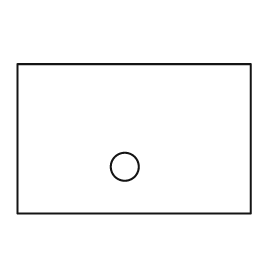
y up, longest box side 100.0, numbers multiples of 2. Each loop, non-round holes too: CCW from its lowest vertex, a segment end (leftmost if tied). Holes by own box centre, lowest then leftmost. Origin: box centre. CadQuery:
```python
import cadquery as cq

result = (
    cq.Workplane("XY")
    .moveTo(-50.0, -32.0)
    .lineTo(50.0, -32.0)
    .lineTo(50.0, 32.0)
    .lineTo(-50.0, 32.0)
    .close()
    .moveTo(-4.0, -12.0)
    .circle(6.0)
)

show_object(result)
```